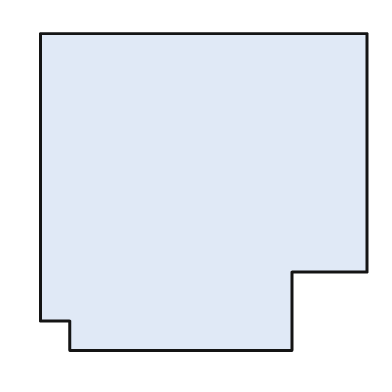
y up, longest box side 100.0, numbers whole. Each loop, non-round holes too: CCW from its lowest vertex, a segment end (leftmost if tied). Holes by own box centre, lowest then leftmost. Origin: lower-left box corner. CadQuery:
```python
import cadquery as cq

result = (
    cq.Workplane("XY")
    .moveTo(9.0, 0.0)
    .lineTo(77.0, 0.0)
    .lineTo(77.0, 24.0)
    .lineTo(100.0, 24.0)
    .lineTo(100.0, 97.0)
    .lineTo(0.0, 97.0)
    .lineTo(0.0, 9.0)
    .lineTo(9.0, 9.0)
    .close()
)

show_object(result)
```